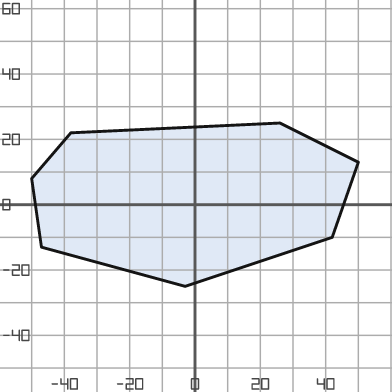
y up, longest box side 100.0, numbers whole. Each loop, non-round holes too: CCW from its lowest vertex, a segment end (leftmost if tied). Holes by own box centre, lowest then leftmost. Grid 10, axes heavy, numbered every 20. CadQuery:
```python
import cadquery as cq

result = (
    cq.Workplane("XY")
    .moveTo(-3.0, -25.0)
    .lineTo(42.0, -10.0)
    .lineTo(50.0, 13.0)
    .lineTo(26.0, 25.0)
    .lineTo(-38.0, 22.0)
    .lineTo(-50.0, 8.0)
    .lineTo(-47.0, -13.0)
    .close()
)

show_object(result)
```